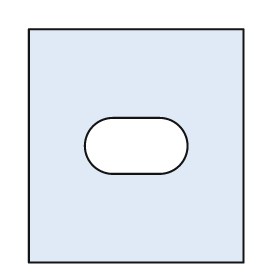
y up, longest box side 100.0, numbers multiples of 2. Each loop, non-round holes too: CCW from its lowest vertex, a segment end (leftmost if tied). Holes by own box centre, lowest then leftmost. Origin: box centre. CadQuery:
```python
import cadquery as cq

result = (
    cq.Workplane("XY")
    .moveTo(-46.0, -50.0)
    .lineTo(46.0, -50.0)
    .lineTo(46.0, 50.0)
    .lineTo(-46.0, 50.0)
    .close()
    .moveTo(-10.0, -12.0)
    .lineTo(10.0, -12.0)
    .threePointArc((22.0, 0.0), (10.0, 12.0))
    .lineTo(-10.0, 12.0)
    .threePointArc((-22.0, 0.0), (-10.0, -12.0))
    .close()
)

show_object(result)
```